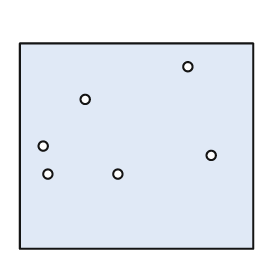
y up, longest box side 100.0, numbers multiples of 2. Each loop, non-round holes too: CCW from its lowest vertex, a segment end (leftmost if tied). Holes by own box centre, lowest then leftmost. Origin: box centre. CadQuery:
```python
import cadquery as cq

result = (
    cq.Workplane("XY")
    .moveTo(-50.0, -44.0)
    .lineTo(50.0, -44.0)
    .lineTo(50.0, 44.0)
    .lineTo(-50.0, 44.0)
    .close()
    .moveTo(-38.0, -12.0)
    .circle(2.0)
    .moveTo(-8.0, -12.0)
    .circle(2.0)
    .moveTo(32.0, -4.0)
    .circle(2.0)
    .moveTo(-40.0, 0.0)
    .circle(2.0)
    .moveTo(-22.0, 20.0)
    .circle(2.0)
    .moveTo(22.0, 34.0)
    .circle(2.0)
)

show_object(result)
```